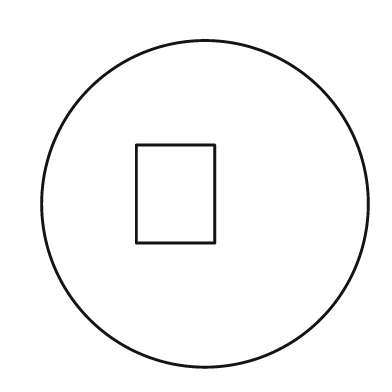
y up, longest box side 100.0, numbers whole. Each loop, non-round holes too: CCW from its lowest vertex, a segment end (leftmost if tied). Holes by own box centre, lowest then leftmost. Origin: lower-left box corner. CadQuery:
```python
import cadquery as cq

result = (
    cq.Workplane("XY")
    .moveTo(50.0, 50.0)
    .circle(50.0)
    .moveTo(29.0, 38.0)
    .lineTo(53.0, 38.0)
    .lineTo(53.0, 68.0)
    .lineTo(29.0, 68.0)
    .close()
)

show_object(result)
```